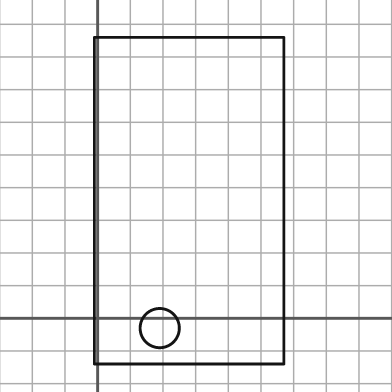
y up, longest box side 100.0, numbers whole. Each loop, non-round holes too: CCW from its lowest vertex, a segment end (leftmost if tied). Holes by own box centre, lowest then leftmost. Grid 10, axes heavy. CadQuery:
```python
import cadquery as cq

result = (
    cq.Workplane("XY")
    .moveTo(-1.0, -14.0)
    .lineTo(57.0, -14.0)
    .lineTo(57.0, 86.0)
    .lineTo(-1.0, 86.0)
    .close()
    .moveTo(19.0, -3.0)
    .circle(6.0)
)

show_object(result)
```